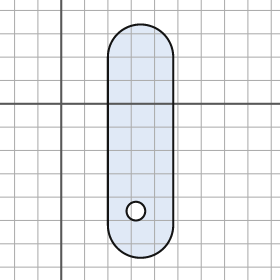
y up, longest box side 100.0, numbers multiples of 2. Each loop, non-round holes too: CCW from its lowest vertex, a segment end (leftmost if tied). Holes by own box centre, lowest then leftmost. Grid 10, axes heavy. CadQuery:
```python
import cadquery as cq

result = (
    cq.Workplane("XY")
    .moveTo(20.0, -52.0)
    .threePointArc((34.0, -66.0), (48.0, -52.0))
    .lineTo(48.0, 20.0)
    .threePointArc((34.0, 34.0), (20.0, 20.0))
    .close()
    .moveTo(32.0, -46.0)
    .circle(4.0)
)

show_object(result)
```